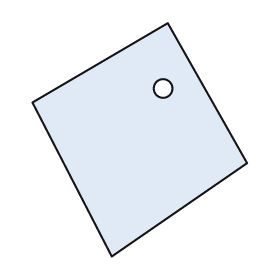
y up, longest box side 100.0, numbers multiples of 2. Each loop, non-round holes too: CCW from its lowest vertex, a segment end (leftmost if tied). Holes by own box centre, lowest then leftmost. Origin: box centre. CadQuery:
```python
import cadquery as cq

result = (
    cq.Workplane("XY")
    .moveTo(-12.0, -50.0)
    .lineTo(46.0, -10.0)
    .lineTo(12.0, 50.0)
    .lineTo(-46.0, 16.0)
    .close()
    .moveTo(10.0, 22.0)
    .circle(4.0)
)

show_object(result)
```